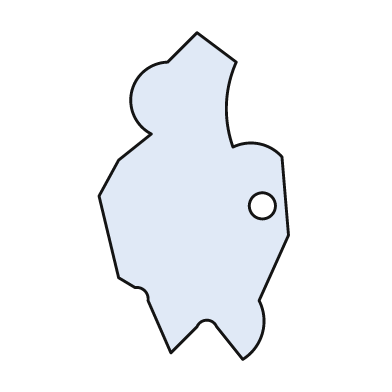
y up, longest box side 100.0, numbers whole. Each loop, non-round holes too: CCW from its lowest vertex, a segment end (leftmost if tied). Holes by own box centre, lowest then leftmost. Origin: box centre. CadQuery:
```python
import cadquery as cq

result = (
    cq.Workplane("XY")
    .moveTo(15.0, -50.0)
    .threePointArc((21.0, -42.0), (20.0, -32.0))
    .lineTo(29.0, -12.0)
    .lineTo(27.0, 12.0)
    .threePointArc((20.0, 16.0), (12.0, 15.0))
    .threePointArc((10.0, 28.0), (13.0, 41.0))
    .lineTo(1.0, 50.0)
    .lineTo(-8.0, 41.0)
    .threePointArc((-19.0, 32.0), (-13.0, 19.0))
    .lineTo(-23.0, 11.0)
    .lineTo(-29.0, 0.0)
    .lineTo(-23.0, -25.0)
    .lineTo(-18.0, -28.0)
    .threePointArc((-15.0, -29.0), (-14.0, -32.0))
    .lineTo(-7.0, -48.0)
    .lineTo(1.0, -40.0)
    .threePointArc((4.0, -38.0), (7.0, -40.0))
    .close()
    .moveTo(21.0, -3.0)
    .circle(4.0)
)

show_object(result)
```